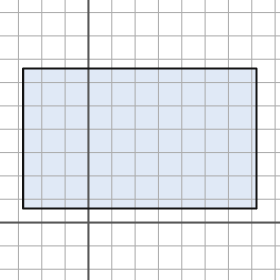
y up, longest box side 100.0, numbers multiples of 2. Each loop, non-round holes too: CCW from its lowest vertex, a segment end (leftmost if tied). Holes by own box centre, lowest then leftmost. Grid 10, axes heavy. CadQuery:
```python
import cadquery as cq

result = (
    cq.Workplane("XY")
    .moveTo(-28.0, 6.0)
    .lineTo(72.0, 6.0)
    .lineTo(72.0, 66.0)
    .lineTo(-28.0, 66.0)
    .close()
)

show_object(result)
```